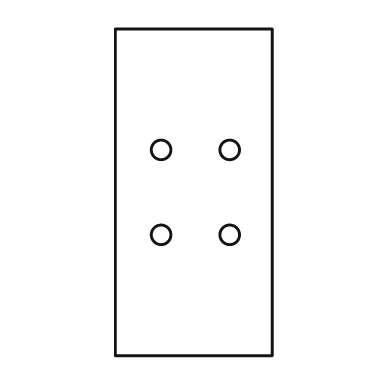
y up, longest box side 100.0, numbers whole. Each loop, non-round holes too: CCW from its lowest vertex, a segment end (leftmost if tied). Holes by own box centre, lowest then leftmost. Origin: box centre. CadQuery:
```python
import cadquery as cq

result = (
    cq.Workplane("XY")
    .moveTo(-24.0, -50.0)
    .lineTo(24.0, -50.0)
    .lineTo(24.0, 50.0)
    .lineTo(-24.0, 50.0)
    .close()
    .moveTo(-10.0, -13.0)
    .circle(3.0)
    .moveTo(11.0, -13.0)
    .circle(3.0)
    .moveTo(-10.0, 13.0)
    .circle(3.0)
    .moveTo(11.0, 13.0)
    .circle(3.0)
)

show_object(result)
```